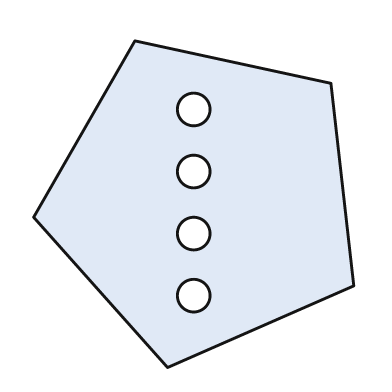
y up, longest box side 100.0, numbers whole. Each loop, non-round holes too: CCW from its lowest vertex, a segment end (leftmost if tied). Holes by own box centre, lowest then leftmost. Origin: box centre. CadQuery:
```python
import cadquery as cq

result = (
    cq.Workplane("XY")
    .moveTo(-8.0, -50.0)
    .lineTo(49.0, -25.0)
    .lineTo(42.0, 37.0)
    .lineTo(-18.0, 50.0)
    .lineTo(-49.0, -4.0)
    .close()
    .moveTo(0.0, -28.0)
    .circle(5.0)
    .moveTo(0.0, -9.0)
    .circle(5.0)
    .moveTo(0.0, 10.0)
    .circle(5.0)
    .moveTo(0.0, 29.0)
    .circle(5.0)
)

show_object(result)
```